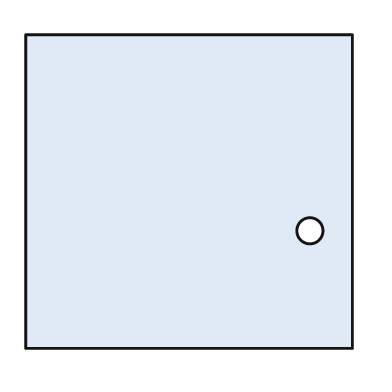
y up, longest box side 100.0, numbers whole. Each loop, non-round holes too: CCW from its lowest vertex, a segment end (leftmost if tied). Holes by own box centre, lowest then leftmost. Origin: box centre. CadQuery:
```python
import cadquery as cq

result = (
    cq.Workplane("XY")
    .moveTo(-50.0, -48.0)
    .lineTo(50.0, -48.0)
    .lineTo(50.0, 48.0)
    .lineTo(-50.0, 48.0)
    .close()
    .moveTo(37.0, -12.0)
    .circle(4.0)
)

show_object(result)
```